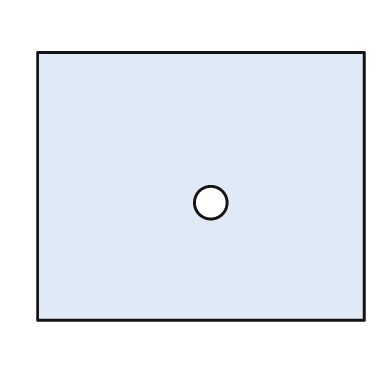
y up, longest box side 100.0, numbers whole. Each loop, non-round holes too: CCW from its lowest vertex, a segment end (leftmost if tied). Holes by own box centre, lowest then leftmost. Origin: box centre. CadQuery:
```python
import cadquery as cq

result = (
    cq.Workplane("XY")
    .moveTo(-50.0, -41.0)
    .lineTo(50.0, -41.0)
    .lineTo(50.0, 41.0)
    .lineTo(-50.0, 41.0)
    .close()
    .moveTo(3.0, -5.0)
    .circle(5.0)
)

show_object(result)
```